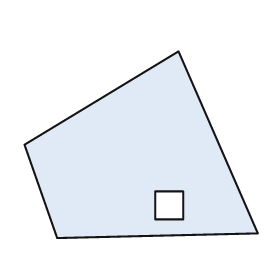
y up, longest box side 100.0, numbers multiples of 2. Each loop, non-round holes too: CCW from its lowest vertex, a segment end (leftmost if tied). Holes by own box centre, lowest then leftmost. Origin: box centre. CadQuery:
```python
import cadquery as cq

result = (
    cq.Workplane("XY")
    .moveTo(-36.0, -40.0)
    .lineTo(50.0, -38.0)
    .lineTo(16.0, 40.0)
    .lineTo(-50.0, 0.0)
    .close()
    .moveTo(6.0, -32.0)
    .lineTo(18.0, -32.0)
    .lineTo(18.0, -20.0)
    .lineTo(6.0, -20.0)
    .close()
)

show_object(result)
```